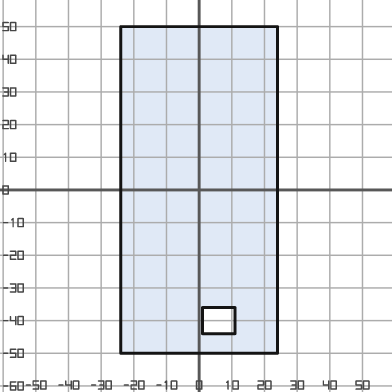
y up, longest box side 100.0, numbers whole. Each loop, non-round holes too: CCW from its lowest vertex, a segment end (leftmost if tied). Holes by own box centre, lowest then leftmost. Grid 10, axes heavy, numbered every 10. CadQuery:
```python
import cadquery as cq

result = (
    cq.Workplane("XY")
    .moveTo(-24.0, -50.0)
    .lineTo(24.0, -50.0)
    .lineTo(24.0, 50.0)
    .lineTo(-24.0, 50.0)
    .close()
    .moveTo(1.0, -44.0)
    .lineTo(11.0, -44.0)
    .lineTo(11.0, -36.0)
    .lineTo(1.0, -36.0)
    .close()
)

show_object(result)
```